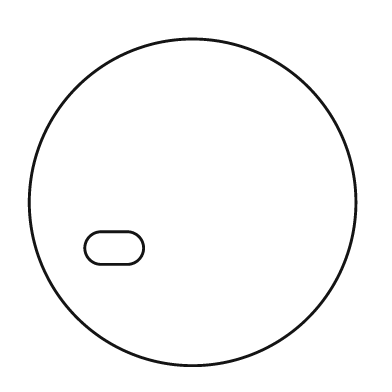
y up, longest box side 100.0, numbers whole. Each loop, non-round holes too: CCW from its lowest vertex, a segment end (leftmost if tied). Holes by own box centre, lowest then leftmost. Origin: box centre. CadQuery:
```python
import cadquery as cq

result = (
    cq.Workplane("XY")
    .moveTo(0.0, 0.0)
    .circle(50.0)
    .moveTo(-28.0, -19.0)
    .lineTo(-20.0, -19.0)
    .threePointArc((-15.0, -14.0), (-20.0, -9.0))
    .lineTo(-28.0, -9.0)
    .threePointArc((-33.0, -14.0), (-28.0, -19.0))
    .close()
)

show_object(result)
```